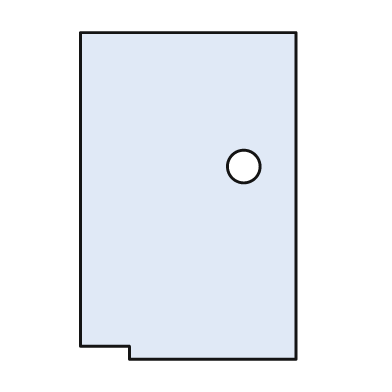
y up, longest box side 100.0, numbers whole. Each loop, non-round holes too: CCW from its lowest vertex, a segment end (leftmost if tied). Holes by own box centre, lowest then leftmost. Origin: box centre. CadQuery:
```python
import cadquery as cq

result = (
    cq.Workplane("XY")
    .moveTo(-18.0, -50.0)
    .lineTo(33.0, -50.0)
    .lineTo(33.0, 50.0)
    .lineTo(-33.0, 50.0)
    .lineTo(-33.0, -46.0)
    .lineTo(-18.0, -46.0)
    .close()
    .moveTo(17.0, 9.0)
    .circle(5.0)
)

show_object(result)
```